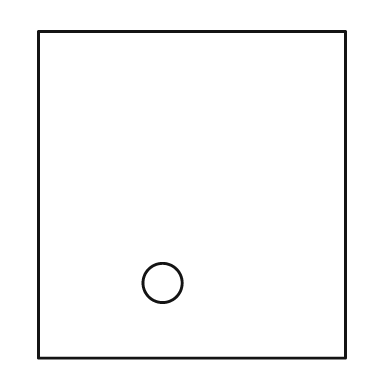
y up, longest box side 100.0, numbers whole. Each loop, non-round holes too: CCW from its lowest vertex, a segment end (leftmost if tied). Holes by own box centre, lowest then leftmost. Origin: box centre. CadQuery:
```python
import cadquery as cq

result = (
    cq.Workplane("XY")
    .moveTo(-47.0, -50.0)
    .lineTo(47.0, -50.0)
    .lineTo(47.0, 50.0)
    .lineTo(-47.0, 50.0)
    .close()
    .moveTo(-9.0, -27.0)
    .circle(6.0)
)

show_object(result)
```